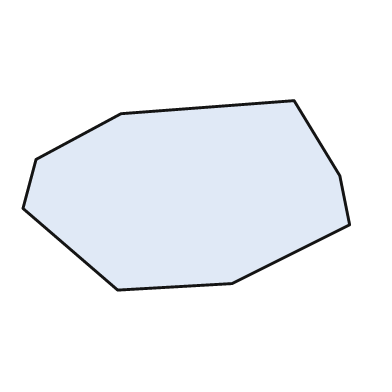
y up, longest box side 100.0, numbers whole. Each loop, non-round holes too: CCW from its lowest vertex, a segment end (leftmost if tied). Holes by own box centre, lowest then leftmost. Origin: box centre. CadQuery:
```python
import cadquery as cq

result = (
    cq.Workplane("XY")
    .moveTo(-21.0, -29.0)
    .lineTo(14.0, -27.0)
    .lineTo(50.0, -9.0)
    .lineTo(47.0, 6.0)
    .lineTo(33.0, 29.0)
    .lineTo(-20.0, 25.0)
    .lineTo(-46.0, 11.0)
    .lineTo(-50.0, -4.0)
    .close()
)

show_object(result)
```